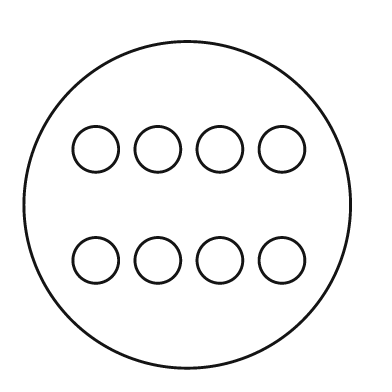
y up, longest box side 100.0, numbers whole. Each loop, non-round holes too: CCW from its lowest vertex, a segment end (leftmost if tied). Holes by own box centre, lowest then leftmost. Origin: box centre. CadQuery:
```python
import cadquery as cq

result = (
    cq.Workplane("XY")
    .moveTo(0.0, 0.0)
    .circle(50.0)
    .moveTo(-28.0, -17.0)
    .circle(7.0)
    .moveTo(-9.0, -17.0)
    .circle(7.0)
    .moveTo(10.0, -17.0)
    .circle(7.0)
    .moveTo(29.0, -17.0)
    .circle(7.0)
    .moveTo(-28.0, 17.0)
    .circle(7.0)
    .moveTo(-9.0, 17.0)
    .circle(7.0)
    .moveTo(10.0, 17.0)
    .circle(7.0)
    .moveTo(29.0, 17.0)
    .circle(7.0)
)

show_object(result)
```